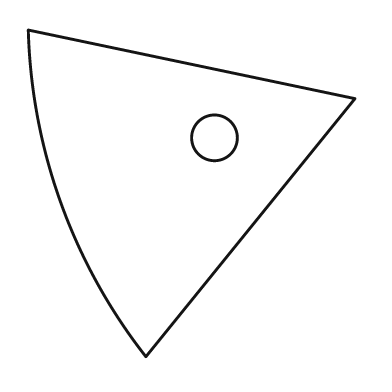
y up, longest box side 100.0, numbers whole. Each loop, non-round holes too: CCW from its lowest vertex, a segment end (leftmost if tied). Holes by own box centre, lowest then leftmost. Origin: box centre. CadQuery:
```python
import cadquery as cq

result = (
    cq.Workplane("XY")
    .moveTo(-14.0, -50.0)
    .lineTo(50.0, 29.0)
    .lineTo(-50.0, 50.0)
    .threePointArc((-40.0, -3.0), (-14.0, -50.0))
    .close()
    .moveTo(7.0, 17.0)
    .circle(7.0)
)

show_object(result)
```